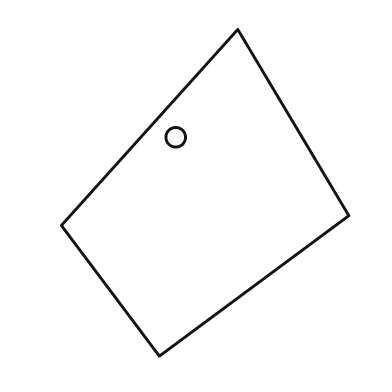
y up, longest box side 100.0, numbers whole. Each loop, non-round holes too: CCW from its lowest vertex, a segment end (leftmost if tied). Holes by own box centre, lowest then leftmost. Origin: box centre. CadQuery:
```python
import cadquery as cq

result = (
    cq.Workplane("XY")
    .moveTo(-14.0, -50.0)
    .lineTo(44.0, -7.0)
    .lineTo(10.0, 50.0)
    .lineTo(-44.0, -10.0)
    .close()
    .moveTo(-9.0, 17.0)
    .circle(3.0)
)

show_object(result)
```